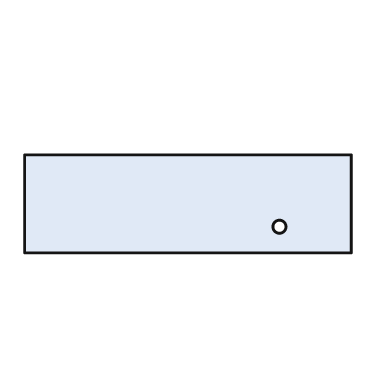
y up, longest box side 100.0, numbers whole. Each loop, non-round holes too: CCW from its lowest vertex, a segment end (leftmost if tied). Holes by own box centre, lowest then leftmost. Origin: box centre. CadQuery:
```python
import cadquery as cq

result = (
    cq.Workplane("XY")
    .moveTo(-50.0, -15.0)
    .lineTo(50.0, -15.0)
    .lineTo(50.0, 15.0)
    .lineTo(-50.0, 15.0)
    .close()
    .moveTo(28.0, -7.0)
    .circle(2.0)
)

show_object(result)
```